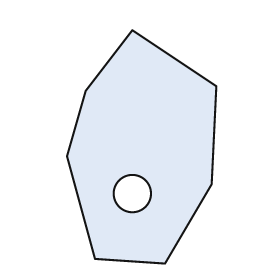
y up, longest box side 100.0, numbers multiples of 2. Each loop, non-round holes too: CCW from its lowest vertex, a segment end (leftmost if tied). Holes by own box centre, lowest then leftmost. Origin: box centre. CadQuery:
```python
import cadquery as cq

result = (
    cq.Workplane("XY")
    .moveTo(10.0, -50.0)
    .lineTo(30.0, -16.0)
    .lineTo(32.0, 26.0)
    .lineTo(-4.0, 50.0)
    .lineTo(-24.0, 24.0)
    .lineTo(-32.0, -4.0)
    .lineTo(-20.0, -48.0)
    .close()
    .moveTo(-4.0, -20.0)
    .circle(8.0)
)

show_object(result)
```